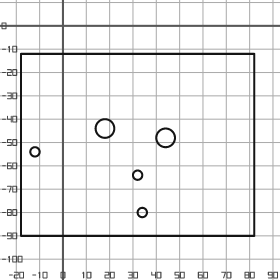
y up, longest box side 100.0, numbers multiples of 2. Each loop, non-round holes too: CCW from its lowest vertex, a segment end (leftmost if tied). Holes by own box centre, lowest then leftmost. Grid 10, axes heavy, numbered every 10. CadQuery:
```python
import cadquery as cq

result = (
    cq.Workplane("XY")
    .moveTo(-18.0, -90.0)
    .lineTo(82.0, -90.0)
    .lineTo(82.0, -12.0)
    .lineTo(-18.0, -12.0)
    .close()
    .moveTo(34.0, -80.0)
    .circle(2.0)
    .moveTo(32.0, -64.0)
    .circle(2.0)
    .moveTo(-12.0, -54.0)
    .circle(2.0)
    .moveTo(44.0, -48.0)
    .circle(4.0)
    .moveTo(18.0, -44.0)
    .circle(4.0)
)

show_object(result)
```